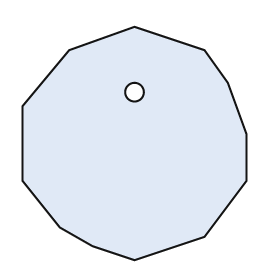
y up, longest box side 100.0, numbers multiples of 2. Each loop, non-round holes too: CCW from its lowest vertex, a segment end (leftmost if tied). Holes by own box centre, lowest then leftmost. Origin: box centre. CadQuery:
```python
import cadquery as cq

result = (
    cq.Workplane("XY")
    .moveTo(0.0, -50.0)
    .lineTo(30.0, -40.0)
    .lineTo(48.0, -16.0)
    .lineTo(48.0, 4.0)
    .lineTo(40.0, 26.0)
    .lineTo(30.0, 40.0)
    .lineTo(0.0, 50.0)
    .lineTo(-28.0, 40.0)
    .lineTo(-48.0, 16.0)
    .lineTo(-48.0, -16.0)
    .lineTo(-32.0, -36.0)
    .lineTo(-18.0, -44.0)
    .close()
    .moveTo(0.0, 22.0)
    .circle(4.0)
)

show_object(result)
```